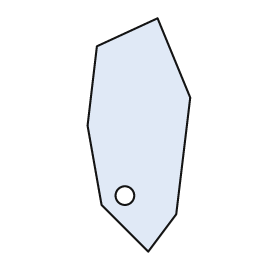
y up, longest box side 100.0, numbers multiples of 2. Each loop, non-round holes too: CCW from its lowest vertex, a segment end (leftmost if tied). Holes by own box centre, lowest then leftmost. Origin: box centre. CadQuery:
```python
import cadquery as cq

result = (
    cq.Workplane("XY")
    .moveTo(4.0, -50.0)
    .lineTo(16.0, -34.0)
    .lineTo(22.0, 16.0)
    .lineTo(8.0, 50.0)
    .lineTo(-18.0, 38.0)
    .lineTo(-22.0, 4.0)
    .lineTo(-16.0, -30.0)
    .close()
    .moveTo(-6.0, -26.0)
    .circle(4.0)
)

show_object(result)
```